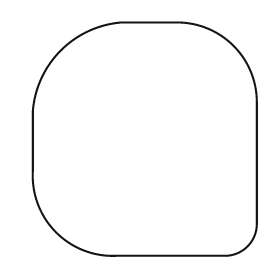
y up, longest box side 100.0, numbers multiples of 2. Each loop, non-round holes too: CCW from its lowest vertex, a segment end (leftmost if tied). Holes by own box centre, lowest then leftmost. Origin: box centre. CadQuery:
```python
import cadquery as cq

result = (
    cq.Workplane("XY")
    .moveTo(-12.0, -50.0)
    .lineTo(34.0, -50.0)
    .threePointArc((44.0, -46.0), (48.0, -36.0))
    .lineTo(48.0, 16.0)
    .threePointArc((38.0, 40.0), (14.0, 50.0))
    .lineTo(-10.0, 50.0)
    .threePointArc((-36.0, 38.0), (-48.0, 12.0))
    .lineTo(-48.0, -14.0)
    .threePointArc((-38.0, -40.0), (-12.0, -50.0))
    .close()
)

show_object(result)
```